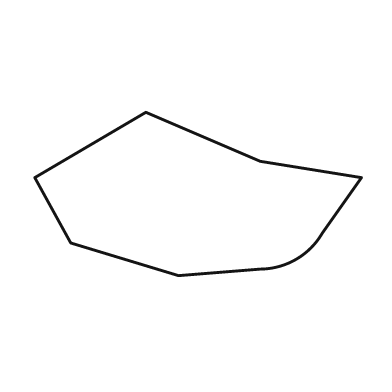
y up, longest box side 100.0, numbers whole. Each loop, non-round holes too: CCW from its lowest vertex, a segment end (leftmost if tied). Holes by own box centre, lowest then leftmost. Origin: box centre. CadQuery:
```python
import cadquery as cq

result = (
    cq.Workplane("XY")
    .moveTo(-6.0, -25.0)
    .lineTo(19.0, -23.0)
    .threePointArc((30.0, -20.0), (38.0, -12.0))
    .lineTo(50.0, 5.0)
    .lineTo(19.0, 10.0)
    .lineTo(-16.0, 25.0)
    .lineTo(-50.0, 5.0)
    .lineTo(-39.0, -15.0)
    .close()
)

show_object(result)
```